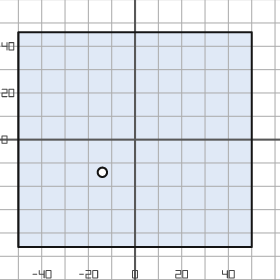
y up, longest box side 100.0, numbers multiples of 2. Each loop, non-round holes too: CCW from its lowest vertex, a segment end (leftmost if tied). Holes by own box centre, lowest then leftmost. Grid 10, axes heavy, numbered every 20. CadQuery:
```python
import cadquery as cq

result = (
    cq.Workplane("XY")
    .moveTo(-50.0, -46.0)
    .lineTo(50.0, -46.0)
    .lineTo(50.0, 46.0)
    .lineTo(-50.0, 46.0)
    .close()
    .moveTo(-14.0, -14.0)
    .circle(2.0)
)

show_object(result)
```